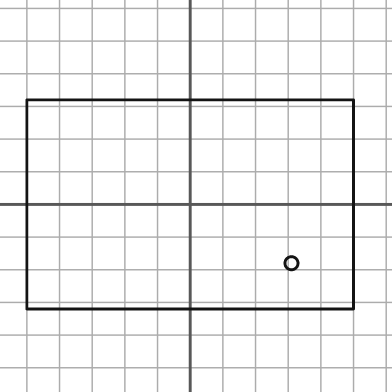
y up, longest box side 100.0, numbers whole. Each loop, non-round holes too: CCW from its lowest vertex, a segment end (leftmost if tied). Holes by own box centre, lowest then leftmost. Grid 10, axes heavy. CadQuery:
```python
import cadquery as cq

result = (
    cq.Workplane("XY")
    .moveTo(-50.0, -32.0)
    .lineTo(50.0, -32.0)
    .lineTo(50.0, 32.0)
    .lineTo(-50.0, 32.0)
    .close()
    .moveTo(31.0, -18.0)
    .circle(2.0)
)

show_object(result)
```